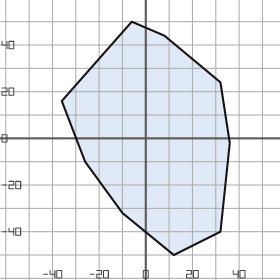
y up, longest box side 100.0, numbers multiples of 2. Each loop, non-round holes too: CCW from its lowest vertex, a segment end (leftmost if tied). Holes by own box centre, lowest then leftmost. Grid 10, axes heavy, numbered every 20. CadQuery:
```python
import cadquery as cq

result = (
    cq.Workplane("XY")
    .moveTo(12.0, -50.0)
    .lineTo(32.0, -40.0)
    .lineTo(36.0, -2.0)
    .lineTo(32.0, 24.0)
    .lineTo(8.0, 44.0)
    .lineTo(-6.0, 50.0)
    .lineTo(-36.0, 16.0)
    .lineTo(-26.0, -10.0)
    .lineTo(-10.0, -32.0)
    .close()
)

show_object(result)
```